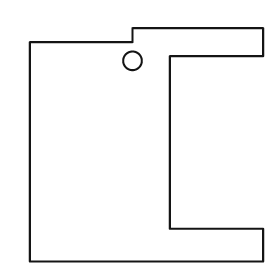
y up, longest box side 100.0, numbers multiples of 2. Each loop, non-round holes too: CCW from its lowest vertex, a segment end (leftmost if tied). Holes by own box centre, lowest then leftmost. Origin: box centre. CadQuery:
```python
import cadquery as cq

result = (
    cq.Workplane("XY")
    .moveTo(-50.0, -50.0)
    .lineTo(50.0, -50.0)
    .lineTo(50.0, -36.0)
    .lineTo(10.0, -36.0)
    .lineTo(10.0, 38.0)
    .lineTo(50.0, 38.0)
    .lineTo(50.0, 50.0)
    .lineTo(-6.0, 50.0)
    .lineTo(-6.0, 44.0)
    .lineTo(-50.0, 44.0)
    .close()
    .moveTo(-6.0, 36.0)
    .circle(4.0)
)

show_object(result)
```